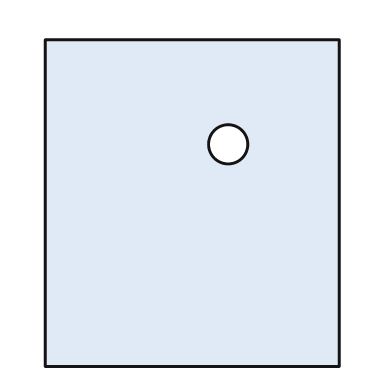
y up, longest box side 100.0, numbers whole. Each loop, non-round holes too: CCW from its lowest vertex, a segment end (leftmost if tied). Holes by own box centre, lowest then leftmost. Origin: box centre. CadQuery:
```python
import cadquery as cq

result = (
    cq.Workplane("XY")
    .moveTo(-45.0, -50.0)
    .lineTo(45.0, -50.0)
    .lineTo(45.0, 50.0)
    .lineTo(-45.0, 50.0)
    .close()
    .moveTo(11.0, 18.0)
    .circle(6.0)
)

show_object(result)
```